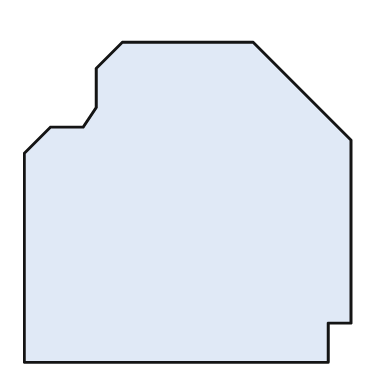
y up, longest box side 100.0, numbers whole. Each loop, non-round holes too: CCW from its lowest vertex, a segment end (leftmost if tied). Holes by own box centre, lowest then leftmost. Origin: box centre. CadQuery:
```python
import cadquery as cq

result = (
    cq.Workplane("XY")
    .moveTo(-50.0, -49.0)
    .lineTo(43.0, -49.0)
    .lineTo(43.0, -37.0)
    .lineTo(50.0, -37.0)
    .lineTo(50.0, 19.0)
    .lineTo(20.0, 49.0)
    .lineTo(-20.0, 49.0)
    .lineTo(-28.0, 41.0)
    .lineTo(-28.0, 29.0)
    .lineTo(-32.0, 23.0)
    .lineTo(-42.0, 23.0)
    .lineTo(-50.0, 15.0)
    .close()
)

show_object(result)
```